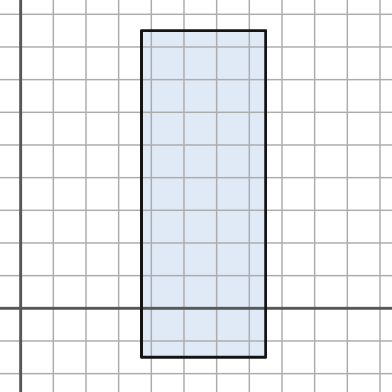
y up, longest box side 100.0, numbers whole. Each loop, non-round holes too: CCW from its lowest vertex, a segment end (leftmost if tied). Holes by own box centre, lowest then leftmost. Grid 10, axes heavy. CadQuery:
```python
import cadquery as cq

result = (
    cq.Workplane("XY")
    .moveTo(37.0, -15.0)
    .lineTo(75.0, -15.0)
    .lineTo(75.0, 85.0)
    .lineTo(37.0, 85.0)
    .close()
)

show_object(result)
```